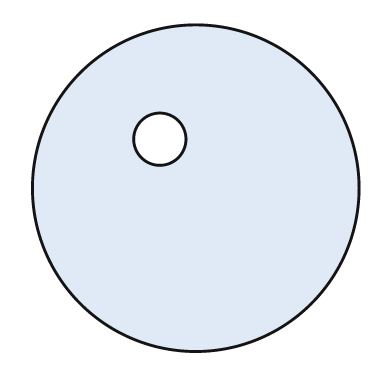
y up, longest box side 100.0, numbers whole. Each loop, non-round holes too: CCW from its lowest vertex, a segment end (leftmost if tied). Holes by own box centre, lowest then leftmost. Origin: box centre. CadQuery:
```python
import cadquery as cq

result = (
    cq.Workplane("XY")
    .moveTo(0.0, 0.0)
    .circle(50.0)
    .moveTo(-11.0, 15.0)
    .circle(8.0)
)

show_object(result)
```